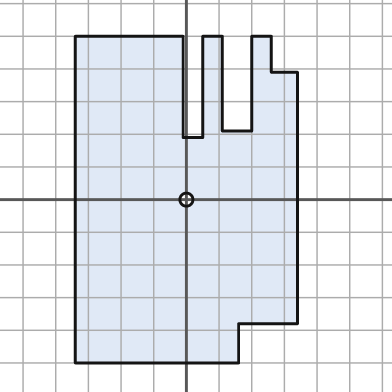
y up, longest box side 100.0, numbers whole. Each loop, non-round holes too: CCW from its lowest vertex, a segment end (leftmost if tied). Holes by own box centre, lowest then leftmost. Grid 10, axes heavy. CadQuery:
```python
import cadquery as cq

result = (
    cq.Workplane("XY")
    .moveTo(-34.0, -50.0)
    .lineTo(16.0, -50.0)
    .lineTo(16.0, -38.0)
    .lineTo(34.0, -38.0)
    .lineTo(34.0, 39.0)
    .lineTo(26.0, 39.0)
    .lineTo(26.0, 50.0)
    .lineTo(20.0, 50.0)
    .lineTo(20.0, 21.0)
    .lineTo(11.0, 21.0)
    .lineTo(11.0, 50.0)
    .lineTo(5.0, 50.0)
    .lineTo(5.0, 19.0)
    .lineTo(-1.0, 19.0)
    .lineTo(-1.0, 50.0)
    .lineTo(-34.0, 50.0)
    .close()
    .moveTo(0.0, 0.0)
    .circle(2.0)
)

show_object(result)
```